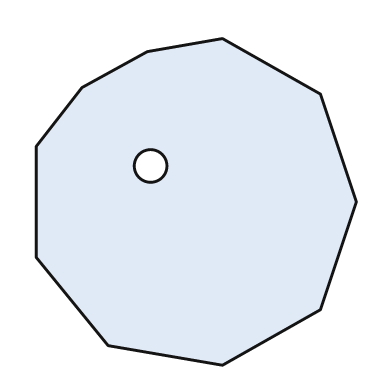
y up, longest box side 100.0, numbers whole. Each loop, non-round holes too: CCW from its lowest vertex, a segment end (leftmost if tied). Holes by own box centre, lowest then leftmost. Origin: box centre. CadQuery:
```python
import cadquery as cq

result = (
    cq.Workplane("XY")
    .moveTo(8.0, -50.0)
    .lineTo(38.0, -33.0)
    .lineTo(49.0, 0.0)
    .lineTo(38.0, 33.0)
    .lineTo(8.0, 50.0)
    .lineTo(-15.0, 46.0)
    .lineTo(-35.0, 35.0)
    .lineTo(-49.0, 17.0)
    .lineTo(-49.0, -17.0)
    .lineTo(-27.0, -44.0)
    .close()
    .moveTo(-14.0, 11.0)
    .circle(5.0)
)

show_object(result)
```